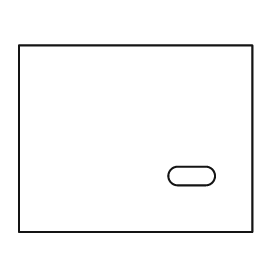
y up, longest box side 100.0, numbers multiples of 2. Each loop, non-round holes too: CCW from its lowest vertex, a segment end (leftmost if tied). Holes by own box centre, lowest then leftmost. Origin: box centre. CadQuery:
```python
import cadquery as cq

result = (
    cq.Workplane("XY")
    .moveTo(-50.0, -40.0)
    .lineTo(50.0, -40.0)
    .lineTo(50.0, 40.0)
    .lineTo(-50.0, 40.0)
    .close()
    .moveTo(18.0, -20.0)
    .lineTo(30.0, -20.0)
    .threePointArc((34.0, -16.0), (30.0, -12.0))
    .lineTo(18.0, -12.0)
    .threePointArc((14.0, -16.0), (18.0, -20.0))
    .close()
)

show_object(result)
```